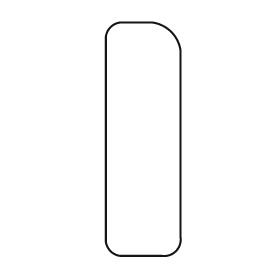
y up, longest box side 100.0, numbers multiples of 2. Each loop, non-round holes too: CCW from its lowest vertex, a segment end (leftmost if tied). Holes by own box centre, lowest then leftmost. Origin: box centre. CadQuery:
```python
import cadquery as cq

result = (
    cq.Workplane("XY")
    .moveTo(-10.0, -50.0)
    .lineTo(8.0, -50.0)
    .threePointArc((14.0, -48.0), (16.0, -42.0))
    .lineTo(16.0, 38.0)
    .threePointArc((12.0, 46.0), (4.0, 50.0))
    .lineTo(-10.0, 50.0)
    .threePointArc((-14.0, 48.0), (-16.0, 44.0))
    .lineTo(-16.0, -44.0)
    .threePointArc((-14.0, -48.0), (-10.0, -50.0))
    .close()
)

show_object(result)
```